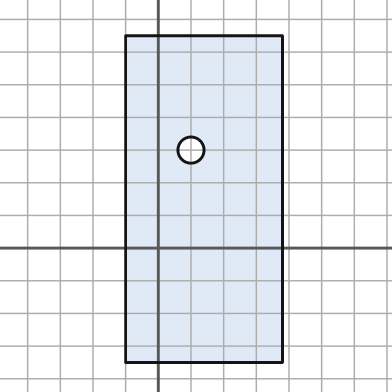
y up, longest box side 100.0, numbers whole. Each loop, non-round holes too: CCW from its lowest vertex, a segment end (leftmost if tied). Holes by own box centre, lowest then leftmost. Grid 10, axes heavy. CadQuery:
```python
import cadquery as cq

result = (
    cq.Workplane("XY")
    .moveTo(-10.0, -35.0)
    .lineTo(38.0, -35.0)
    .lineTo(38.0, 65.0)
    .lineTo(-10.0, 65.0)
    .close()
    .moveTo(10.0, 30.0)
    .circle(4.0)
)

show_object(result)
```